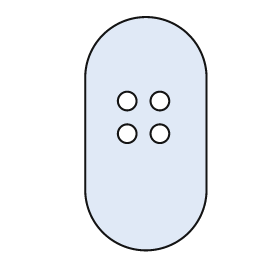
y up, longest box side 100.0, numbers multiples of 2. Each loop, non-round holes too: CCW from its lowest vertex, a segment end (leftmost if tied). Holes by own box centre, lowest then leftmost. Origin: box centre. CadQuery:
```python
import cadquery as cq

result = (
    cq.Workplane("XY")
    .moveTo(-26.0, -24.0)
    .threePointArc((0.0, -50.0), (26.0, -24.0))
    .lineTo(26.0, 24.0)
    .threePointArc((0.0, 50.0), (-26.0, 24.0))
    .close()
    .moveTo(-8.0, 0.0)
    .circle(4.0)
    .moveTo(6.0, 0.0)
    .circle(4.0)
    .moveTo(-8.0, 14.0)
    .circle(4.0)
    .moveTo(6.0, 14.0)
    .circle(4.0)
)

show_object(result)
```